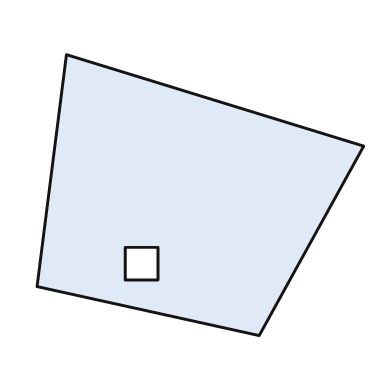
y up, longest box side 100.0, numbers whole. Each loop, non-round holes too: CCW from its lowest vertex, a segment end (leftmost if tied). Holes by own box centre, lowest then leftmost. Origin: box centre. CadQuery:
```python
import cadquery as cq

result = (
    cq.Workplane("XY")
    .moveTo(18.0, -43.0)
    .lineTo(50.0, 15.0)
    .lineTo(-41.0, 43.0)
    .lineTo(-50.0, -28.0)
    .close()
    .moveTo(-23.0, -26.0)
    .lineTo(-13.0, -26.0)
    .lineTo(-13.0, -16.0)
    .lineTo(-23.0, -16.0)
    .close()
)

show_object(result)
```